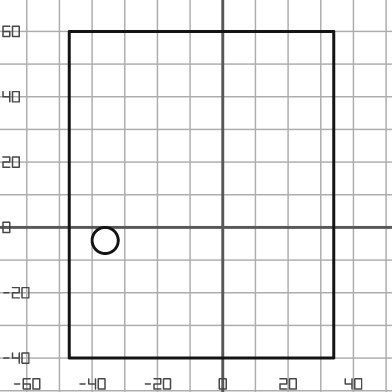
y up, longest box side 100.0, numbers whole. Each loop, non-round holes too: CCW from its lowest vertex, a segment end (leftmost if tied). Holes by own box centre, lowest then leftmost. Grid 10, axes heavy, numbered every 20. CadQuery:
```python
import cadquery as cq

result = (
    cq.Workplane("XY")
    .moveTo(-47.0, -40.0)
    .lineTo(34.0, -40.0)
    .lineTo(34.0, 60.0)
    .lineTo(-47.0, 60.0)
    .close()
    .moveTo(-36.0, -4.0)
    .circle(4.0)
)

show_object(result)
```